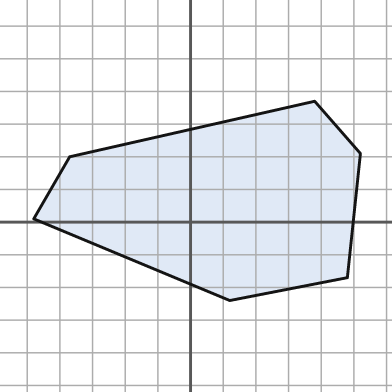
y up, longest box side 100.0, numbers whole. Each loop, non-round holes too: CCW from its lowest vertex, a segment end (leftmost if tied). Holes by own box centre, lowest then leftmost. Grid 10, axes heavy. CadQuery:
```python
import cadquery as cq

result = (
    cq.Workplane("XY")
    .moveTo(12.0, -24.0)
    .lineTo(48.0, -17.0)
    .lineTo(52.0, 21.0)
    .lineTo(38.0, 37.0)
    .lineTo(-37.0, 20.0)
    .lineTo(-48.0, 1.0)
    .close()
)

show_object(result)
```